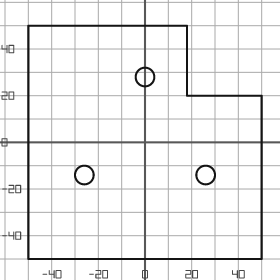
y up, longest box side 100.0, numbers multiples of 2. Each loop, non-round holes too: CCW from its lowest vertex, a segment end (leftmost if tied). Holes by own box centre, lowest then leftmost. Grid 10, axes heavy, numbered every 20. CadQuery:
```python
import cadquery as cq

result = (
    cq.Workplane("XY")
    .moveTo(-50.0, -50.0)
    .lineTo(50.0, -50.0)
    .lineTo(50.0, 20.0)
    .lineTo(18.0, 20.0)
    .lineTo(18.0, 50.0)
    .lineTo(-50.0, 50.0)
    .close()
    .moveTo(-26.0, -14.0)
    .circle(4.0)
    .moveTo(26.0, -14.0)
    .circle(4.0)
    .moveTo(0.0, 28.0)
    .circle(4.0)
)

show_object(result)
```